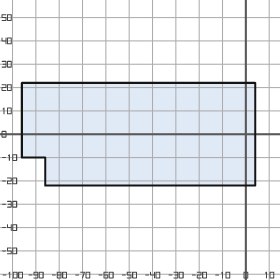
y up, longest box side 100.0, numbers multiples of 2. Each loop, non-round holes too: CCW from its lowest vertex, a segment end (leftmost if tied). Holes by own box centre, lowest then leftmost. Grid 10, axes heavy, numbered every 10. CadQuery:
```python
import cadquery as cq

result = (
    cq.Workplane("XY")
    .moveTo(-86.0, -22.0)
    .lineTo(4.0, -22.0)
    .lineTo(4.0, 22.0)
    .lineTo(-96.0, 22.0)
    .lineTo(-96.0, -10.0)
    .lineTo(-86.0, -10.0)
    .close()
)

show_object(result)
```